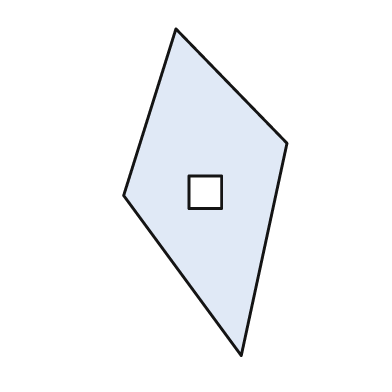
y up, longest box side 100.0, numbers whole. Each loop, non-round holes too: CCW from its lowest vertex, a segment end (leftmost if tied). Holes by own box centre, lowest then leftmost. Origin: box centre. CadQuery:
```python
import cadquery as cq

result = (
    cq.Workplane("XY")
    .moveTo(11.0, -50.0)
    .lineTo(25.0, 15.0)
    .lineTo(-9.0, 50.0)
    .lineTo(-25.0, -1.0)
    .close()
    .moveTo(-5.0, -5.0)
    .lineTo(5.0, -5.0)
    .lineTo(5.0, 5.0)
    .lineTo(-5.0, 5.0)
    .close()
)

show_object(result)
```